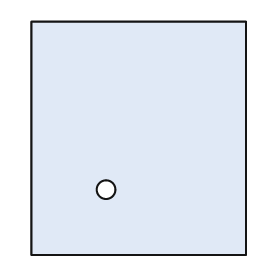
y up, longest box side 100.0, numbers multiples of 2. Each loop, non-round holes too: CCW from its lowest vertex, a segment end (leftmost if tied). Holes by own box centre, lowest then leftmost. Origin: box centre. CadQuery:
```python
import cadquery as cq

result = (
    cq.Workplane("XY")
    .moveTo(-46.0, -50.0)
    .lineTo(46.0, -50.0)
    .lineTo(46.0, 50.0)
    .lineTo(-46.0, 50.0)
    .close()
    .moveTo(-14.0, -22.0)
    .circle(4.0)
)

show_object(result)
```